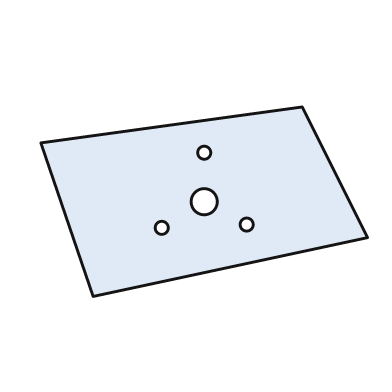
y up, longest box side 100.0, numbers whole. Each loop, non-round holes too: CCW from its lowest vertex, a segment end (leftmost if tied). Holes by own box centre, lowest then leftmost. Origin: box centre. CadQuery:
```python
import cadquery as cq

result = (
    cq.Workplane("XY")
    .moveTo(-34.0, -29.0)
    .lineTo(50.0, -11.0)
    .lineTo(30.0, 29.0)
    .lineTo(-50.0, 18.0)
    .close()
    .moveTo(-13.0, -8.0)
    .circle(2.0)
    .moveTo(13.0, -7.0)
    .circle(2.0)
    .moveTo(0.0, 0.0)
    .circle(4.0)
    .moveTo(0.0, 15.0)
    .circle(2.0)
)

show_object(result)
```